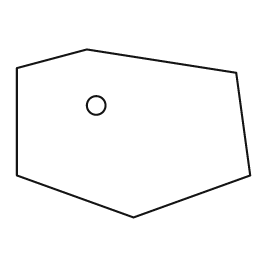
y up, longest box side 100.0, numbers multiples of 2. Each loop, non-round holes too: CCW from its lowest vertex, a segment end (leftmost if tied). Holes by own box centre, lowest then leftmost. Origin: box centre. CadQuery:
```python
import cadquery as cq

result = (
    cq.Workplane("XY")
    .moveTo(0.0, -36.0)
    .lineTo(50.0, -18.0)
    .lineTo(44.0, 26.0)
    .lineTo(-20.0, 36.0)
    .lineTo(-50.0, 28.0)
    .lineTo(-50.0, -18.0)
    .close()
    .moveTo(-16.0, 12.0)
    .circle(4.0)
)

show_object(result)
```